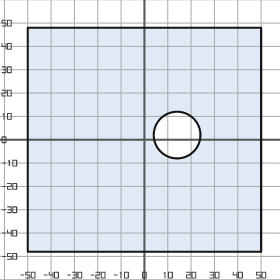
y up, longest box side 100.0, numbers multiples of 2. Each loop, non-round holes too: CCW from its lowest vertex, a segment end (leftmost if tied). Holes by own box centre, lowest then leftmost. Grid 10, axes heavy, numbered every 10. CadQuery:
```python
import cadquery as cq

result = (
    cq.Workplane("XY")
    .moveTo(-50.0, -48.0)
    .lineTo(50.0, -48.0)
    .lineTo(50.0, 48.0)
    .lineTo(-50.0, 48.0)
    .close()
    .moveTo(14.0, 2.0)
    .circle(10.0)
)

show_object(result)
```